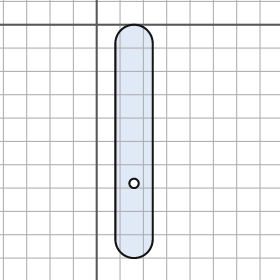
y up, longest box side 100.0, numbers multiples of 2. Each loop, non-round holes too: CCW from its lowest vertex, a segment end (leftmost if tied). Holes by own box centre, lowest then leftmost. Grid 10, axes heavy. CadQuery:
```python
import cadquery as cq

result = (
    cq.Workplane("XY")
    .moveTo(8.0, -92.0)
    .threePointArc((16.0, -100.0), (24.0, -92.0))
    .lineTo(24.0, -8.0)
    .threePointArc((16.0, 0.0), (8.0, -8.0))
    .close()
    .moveTo(16.0, -68.0)
    .circle(2.0)
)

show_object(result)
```